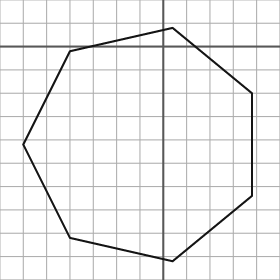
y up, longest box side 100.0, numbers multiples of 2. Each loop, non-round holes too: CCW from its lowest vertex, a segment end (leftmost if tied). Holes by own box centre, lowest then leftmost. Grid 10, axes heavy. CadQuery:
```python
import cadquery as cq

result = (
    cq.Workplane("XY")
    .moveTo(4.0, -92.0)
    .lineTo(38.0, -64.0)
    .lineTo(38.0, -20.0)
    .lineTo(4.0, 8.0)
    .lineTo(-40.0, -2.0)
    .lineTo(-60.0, -42.0)
    .lineTo(-40.0, -82.0)
    .close()
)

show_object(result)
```